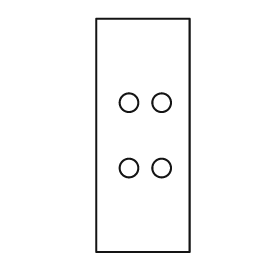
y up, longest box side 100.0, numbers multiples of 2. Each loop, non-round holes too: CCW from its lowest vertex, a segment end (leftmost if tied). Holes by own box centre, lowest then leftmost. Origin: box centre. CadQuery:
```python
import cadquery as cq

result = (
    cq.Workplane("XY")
    .moveTo(-20.0, -50.0)
    .lineTo(20.0, -50.0)
    .lineTo(20.0, 50.0)
    .lineTo(-20.0, 50.0)
    .close()
    .moveTo(-6.0, -14.0)
    .circle(4.0)
    .moveTo(8.0, -14.0)
    .circle(4.0)
    .moveTo(-6.0, 14.0)
    .circle(4.0)
    .moveTo(8.0, 14.0)
    .circle(4.0)
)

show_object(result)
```